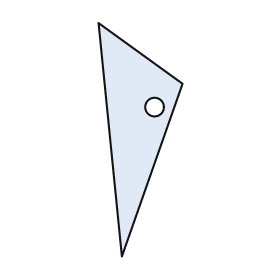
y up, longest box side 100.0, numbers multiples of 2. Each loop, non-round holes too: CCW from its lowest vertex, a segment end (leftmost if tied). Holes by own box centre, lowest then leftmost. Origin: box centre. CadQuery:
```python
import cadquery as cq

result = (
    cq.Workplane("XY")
    .moveTo(-8.0, -50.0)
    .lineTo(18.0, 24.0)
    .lineTo(-18.0, 50.0)
    .close()
    .moveTo(6.0, 14.0)
    .circle(4.0)
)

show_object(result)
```